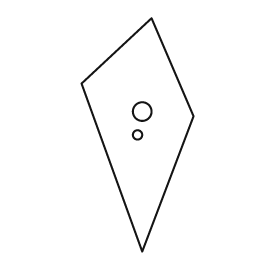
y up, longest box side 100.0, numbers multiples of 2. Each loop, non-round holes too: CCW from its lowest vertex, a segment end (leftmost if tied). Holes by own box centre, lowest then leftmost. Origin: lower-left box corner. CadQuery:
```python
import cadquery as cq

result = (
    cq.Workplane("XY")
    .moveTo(26.0, 0.0)
    .lineTo(48.0, 58.0)
    .lineTo(30.0, 100.0)
    .lineTo(0.0, 72.0)
    .close()
    .moveTo(24.0, 50.0)
    .circle(2.0)
    .moveTo(26.0, 60.0)
    .circle(4.0)
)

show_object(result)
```